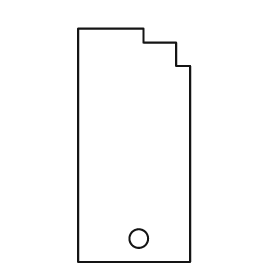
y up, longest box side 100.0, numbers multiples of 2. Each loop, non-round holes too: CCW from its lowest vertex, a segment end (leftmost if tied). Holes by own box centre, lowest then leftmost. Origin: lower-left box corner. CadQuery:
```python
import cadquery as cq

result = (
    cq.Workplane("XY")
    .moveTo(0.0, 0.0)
    .lineTo(48.0, 0.0)
    .lineTo(48.0, 84.0)
    .lineTo(42.0, 84.0)
    .lineTo(42.0, 94.0)
    .lineTo(28.0, 94.0)
    .lineTo(28.0, 100.0)
    .lineTo(0.0, 100.0)
    .close()
    .moveTo(26.0, 10.0)
    .circle(4.0)
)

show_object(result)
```